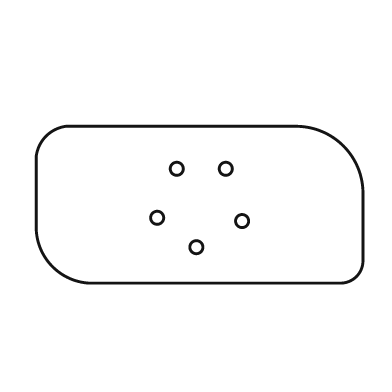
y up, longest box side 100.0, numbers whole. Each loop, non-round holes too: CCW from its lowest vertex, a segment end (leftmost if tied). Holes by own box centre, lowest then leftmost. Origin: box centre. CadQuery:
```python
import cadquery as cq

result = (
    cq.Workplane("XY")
    .moveTo(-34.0, -24.0)
    .lineTo(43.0, -24.0)
    .threePointArc((48.0, -22.0), (50.0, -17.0))
    .lineTo(50.0, 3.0)
    .threePointArc((44.0, 18.0), (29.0, 24.0))
    .lineTo(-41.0, 24.0)
    .threePointArc((-47.0, 21.0), (-50.0, 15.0))
    .lineTo(-50.0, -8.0)
    .threePointArc((-45.0, -19.0), (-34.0, -24.0))
    .close()
    .moveTo(-1.0, -13.0)
    .circle(2.0)
    .moveTo(13.0, -5.0)
    .circle(2.0)
    .moveTo(-13.0, -4.0)
    .circle(2.0)
    .moveTo(-7.0, 11.0)
    .circle(2.0)
    .moveTo(8.0, 11.0)
    .circle(2.0)
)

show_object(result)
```